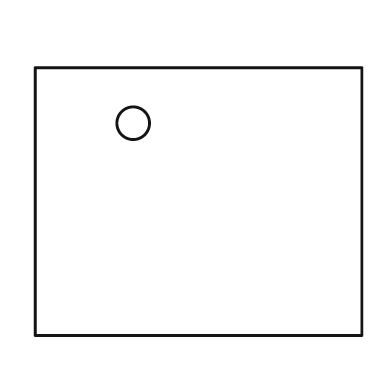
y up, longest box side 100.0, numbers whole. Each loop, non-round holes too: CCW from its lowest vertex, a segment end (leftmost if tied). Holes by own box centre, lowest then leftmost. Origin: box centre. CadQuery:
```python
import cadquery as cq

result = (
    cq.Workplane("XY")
    .moveTo(-50.0, -41.0)
    .lineTo(50.0, -41.0)
    .lineTo(50.0, 41.0)
    .lineTo(-50.0, 41.0)
    .close()
    .moveTo(-20.0, 24.0)
    .circle(5.0)
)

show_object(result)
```